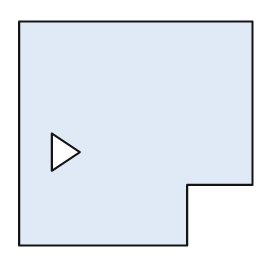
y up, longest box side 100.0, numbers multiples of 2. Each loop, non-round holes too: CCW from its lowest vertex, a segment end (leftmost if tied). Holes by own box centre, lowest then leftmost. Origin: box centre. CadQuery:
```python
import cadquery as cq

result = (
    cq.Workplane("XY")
    .moveTo(-50.0, -48.0)
    .lineTo(22.0, -48.0)
    .lineTo(22.0, -22.0)
    .lineTo(50.0, -22.0)
    .lineTo(50.0, 48.0)
    .lineTo(-50.0, 48.0)
    .close()
    .moveTo(-36.0, -16.0)
    .lineTo(-24.0, -8.0)
    .lineTo(-36.0, 0.0)
    .close()
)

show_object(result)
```